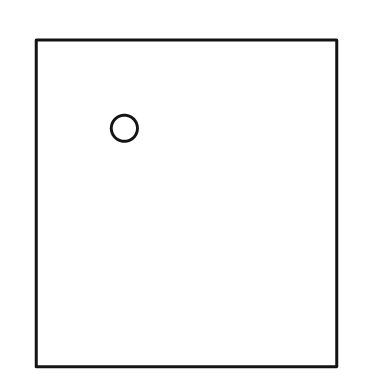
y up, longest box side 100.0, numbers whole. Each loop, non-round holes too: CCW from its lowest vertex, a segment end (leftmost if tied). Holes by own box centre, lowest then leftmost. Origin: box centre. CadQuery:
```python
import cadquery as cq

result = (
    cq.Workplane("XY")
    .moveTo(-46.0, -50.0)
    .lineTo(46.0, -50.0)
    .lineTo(46.0, 50.0)
    .lineTo(-46.0, 50.0)
    .close()
    .moveTo(-19.0, 23.0)
    .circle(4.0)
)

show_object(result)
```